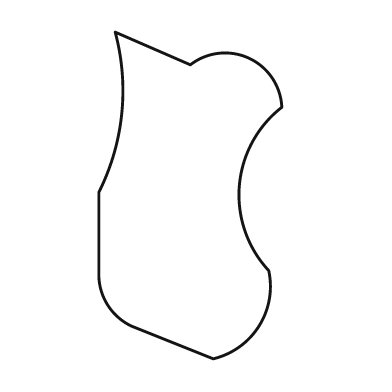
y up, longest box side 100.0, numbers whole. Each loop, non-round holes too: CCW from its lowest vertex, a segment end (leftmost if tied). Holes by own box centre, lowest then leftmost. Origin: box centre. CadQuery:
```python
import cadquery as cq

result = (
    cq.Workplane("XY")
    .moveTo(7.0, -50.0)
    .threePointArc((21.0, -40.0), (24.0, -23.0))
    .threePointArc((15.0, 3.0), (28.0, 27.0))
    .threePointArc((18.0, 42.0), (0.0, 40.0))
    .lineTo(-23.0, 50.0)
    .threePointArc((-21.0, 25.0), (-28.0, 1.0))
    .lineTo(-28.0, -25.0)
    .threePointArc((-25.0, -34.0), (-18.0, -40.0))
    .close()
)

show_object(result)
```